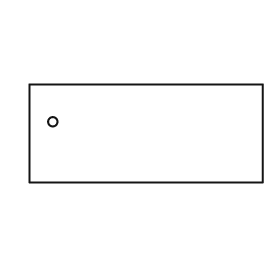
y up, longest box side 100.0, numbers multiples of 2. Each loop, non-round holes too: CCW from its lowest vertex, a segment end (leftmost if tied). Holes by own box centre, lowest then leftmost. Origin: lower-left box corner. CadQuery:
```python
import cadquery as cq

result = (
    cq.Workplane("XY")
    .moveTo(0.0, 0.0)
    .lineTo(100.0, 0.0)
    .lineTo(100.0, 42.0)
    .lineTo(0.0, 42.0)
    .close()
    .moveTo(10.0, 26.0)
    .circle(2.0)
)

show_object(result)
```